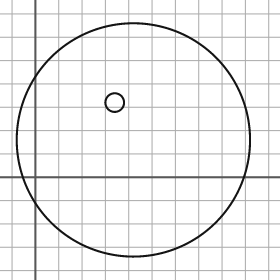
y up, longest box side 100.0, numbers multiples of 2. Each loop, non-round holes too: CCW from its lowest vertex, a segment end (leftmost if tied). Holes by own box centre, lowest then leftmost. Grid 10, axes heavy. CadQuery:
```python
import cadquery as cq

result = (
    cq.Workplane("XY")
    .moveTo(42.0, 16.0)
    .circle(50.0)
    .moveTo(34.0, 32.0)
    .circle(4.0)
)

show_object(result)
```